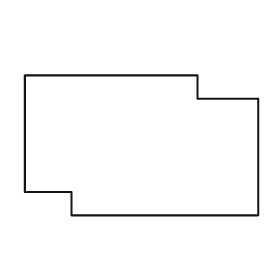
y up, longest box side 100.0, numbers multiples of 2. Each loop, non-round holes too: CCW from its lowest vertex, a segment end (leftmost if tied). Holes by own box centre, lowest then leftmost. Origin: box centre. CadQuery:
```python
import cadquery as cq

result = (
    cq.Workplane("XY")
    .moveTo(-30.0, -30.0)
    .lineTo(50.0, -30.0)
    .lineTo(50.0, 20.0)
    .lineTo(24.0, 20.0)
    .lineTo(24.0, 30.0)
    .lineTo(-50.0, 30.0)
    .lineTo(-50.0, -20.0)
    .lineTo(-30.0, -20.0)
    .close()
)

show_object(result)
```